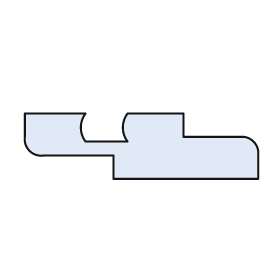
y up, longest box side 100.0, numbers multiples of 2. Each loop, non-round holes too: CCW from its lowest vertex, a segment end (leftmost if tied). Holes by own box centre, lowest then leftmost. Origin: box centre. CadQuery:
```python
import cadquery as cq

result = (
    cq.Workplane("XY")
    .moveTo(-12.0, -14.0)
    .lineTo(50.0, -14.0)
    .lineTo(50.0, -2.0)
    .threePointArc((48.0, 2.0), (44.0, 4.0))
    .lineTo(18.0, 4.0)
    .lineTo(18.0, 14.0)
    .lineTo(-6.0, 14.0)
    .threePointArc((-8.0, 8.0), (-6.0, 2.0))
    .lineTo(-24.0, 2.0)
    .threePointArc((-26.0, 8.0), (-24.0, 14.0))
    .lineTo(-50.0, 14.0)
    .lineTo(-50.0, 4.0)
    .threePointArc((-48.0, -2.0), (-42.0, -4.0))
    .lineTo(-12.0, -4.0)
    .close()
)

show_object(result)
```